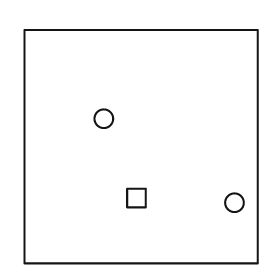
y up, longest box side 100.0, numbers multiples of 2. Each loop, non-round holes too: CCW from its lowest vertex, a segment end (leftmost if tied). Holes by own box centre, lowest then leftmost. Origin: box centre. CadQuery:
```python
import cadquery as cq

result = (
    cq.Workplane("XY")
    .moveTo(-50.0, -50.0)
    .lineTo(50.0, -50.0)
    .lineTo(50.0, 50.0)
    .lineTo(-50.0, 50.0)
    .close()
    .moveTo(40.0, -24.0)
    .circle(4.0)
    .moveTo(-6.0, -26.0)
    .lineTo(2.0, -26.0)
    .lineTo(2.0, -18.0)
    .lineTo(-6.0, -18.0)
    .close()
    .moveTo(-16.0, 12.0)
    .circle(4.0)
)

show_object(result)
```